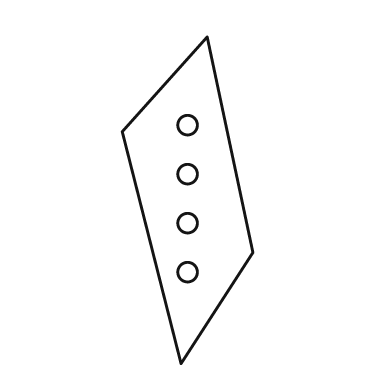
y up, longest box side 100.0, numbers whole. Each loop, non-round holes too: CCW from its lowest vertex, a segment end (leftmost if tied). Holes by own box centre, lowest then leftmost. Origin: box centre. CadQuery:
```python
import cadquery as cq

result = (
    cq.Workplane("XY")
    .moveTo(-2.0, -50.0)
    .lineTo(20.0, -16.0)
    .lineTo(6.0, 50.0)
    .lineTo(-20.0, 21.0)
    .close()
    .moveTo(0.0, -22.0)
    .circle(3.0)
    .moveTo(0.0, -7.0)
    .circle(3.0)
    .moveTo(0.0, 8.0)
    .circle(3.0)
    .moveTo(0.0, 23.0)
    .circle(3.0)
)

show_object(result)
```